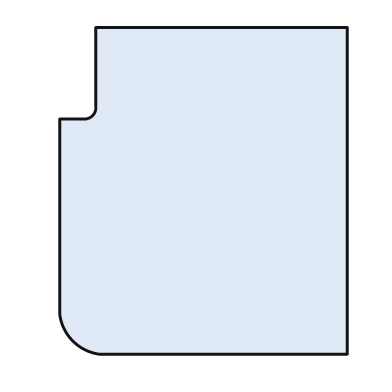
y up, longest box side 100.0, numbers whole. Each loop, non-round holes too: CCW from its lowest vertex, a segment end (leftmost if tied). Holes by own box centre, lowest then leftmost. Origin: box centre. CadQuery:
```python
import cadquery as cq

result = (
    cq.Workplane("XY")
    .moveTo(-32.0, -50.0)
    .lineTo(44.0, -50.0)
    .lineTo(44.0, 50.0)
    .lineTo(-33.0, 50.0)
    .lineTo(-33.0, 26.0)
    .threePointArc((-34.0, 23.0), (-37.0, 22.0))
    .lineTo(-44.0, 22.0)
    .lineTo(-44.0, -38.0)
    .threePointArc((-40.0, -46.0), (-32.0, -50.0))
    .close()
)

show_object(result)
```